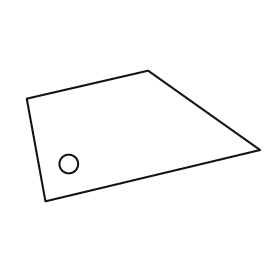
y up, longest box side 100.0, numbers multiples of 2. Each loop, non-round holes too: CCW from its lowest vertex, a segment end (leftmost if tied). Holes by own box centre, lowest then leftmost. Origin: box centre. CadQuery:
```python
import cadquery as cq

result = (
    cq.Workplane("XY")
    .moveTo(-42.0, -28.0)
    .lineTo(50.0, -6.0)
    .lineTo(2.0, 28.0)
    .lineTo(-50.0, 16.0)
    .close()
    .moveTo(-32.0, -12.0)
    .circle(4.0)
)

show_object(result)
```